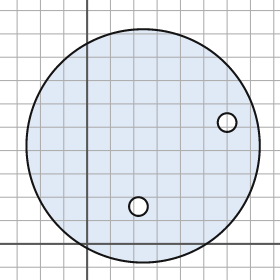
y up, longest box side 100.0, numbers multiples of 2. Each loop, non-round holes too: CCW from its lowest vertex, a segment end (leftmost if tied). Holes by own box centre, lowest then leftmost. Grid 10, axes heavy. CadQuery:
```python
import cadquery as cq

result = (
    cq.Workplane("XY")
    .moveTo(24.0, 42.0)
    .circle(50.0)
    .moveTo(22.0, 16.0)
    .circle(4.0)
    .moveTo(60.0, 52.0)
    .circle(4.0)
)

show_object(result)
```